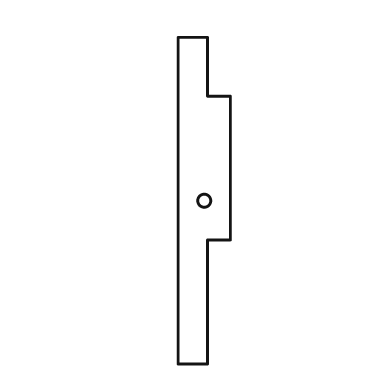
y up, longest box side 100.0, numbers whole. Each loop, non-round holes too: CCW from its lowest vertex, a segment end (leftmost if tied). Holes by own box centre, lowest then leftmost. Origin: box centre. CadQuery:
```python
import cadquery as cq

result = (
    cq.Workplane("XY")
    .moveTo(-8.0, -50.0)
    .lineTo(1.0, -50.0)
    .lineTo(1.0, -12.0)
    .lineTo(8.0, -12.0)
    .lineTo(8.0, 32.0)
    .lineTo(1.0, 32.0)
    .lineTo(1.0, 50.0)
    .lineTo(-8.0, 50.0)
    .close()
    .moveTo(0.0, 0.0)
    .circle(2.0)
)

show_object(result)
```